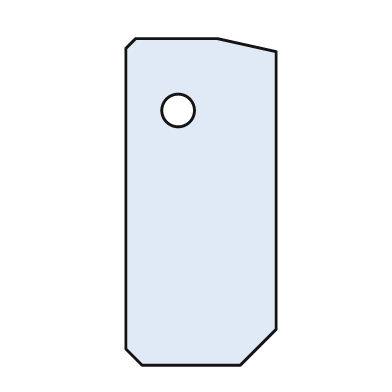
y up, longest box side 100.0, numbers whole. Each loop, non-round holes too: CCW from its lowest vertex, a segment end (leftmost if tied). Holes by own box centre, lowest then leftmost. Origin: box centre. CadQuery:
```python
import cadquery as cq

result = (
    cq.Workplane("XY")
    .moveTo(-18.0, -50.0)
    .lineTo(12.0, -50.0)
    .lineTo(23.0, -39.0)
    .lineTo(23.0, 46.0)
    .lineTo(5.0, 50.0)
    .lineTo(-20.0, 50.0)
    .lineTo(-23.0, 47.0)
    .lineTo(-23.0, -45.0)
    .close()
    .moveTo(-7.0, 28.0)
    .circle(5.0)
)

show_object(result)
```